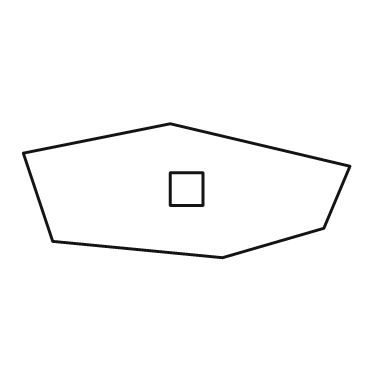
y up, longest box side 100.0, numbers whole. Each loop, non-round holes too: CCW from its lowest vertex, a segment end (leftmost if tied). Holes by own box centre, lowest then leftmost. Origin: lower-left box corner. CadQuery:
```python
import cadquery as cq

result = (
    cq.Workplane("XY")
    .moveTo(61.0, 0.0)
    .lineTo(92.0, 9.0)
    .lineTo(100.0, 28.0)
    .lineTo(45.0, 41.0)
    .lineTo(0.0, 32.0)
    .lineTo(9.0, 5.0)
    .close()
    .moveTo(45.0, 16.0)
    .lineTo(55.0, 16.0)
    .lineTo(55.0, 26.0)
    .lineTo(45.0, 26.0)
    .close()
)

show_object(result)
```